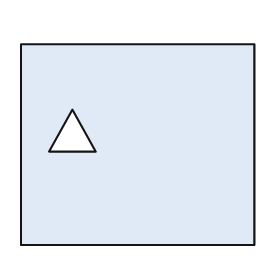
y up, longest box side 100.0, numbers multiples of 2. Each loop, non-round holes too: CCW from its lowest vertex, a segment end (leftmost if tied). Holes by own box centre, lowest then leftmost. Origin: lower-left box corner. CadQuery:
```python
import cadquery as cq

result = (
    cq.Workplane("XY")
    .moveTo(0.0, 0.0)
    .lineTo(100.0, 0.0)
    .lineTo(100.0, 86.0)
    .lineTo(0.0, 86.0)
    .close()
    .moveTo(12.0, 40.0)
    .lineTo(32.0, 40.0)
    .lineTo(22.0, 58.0)
    .close()
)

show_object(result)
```